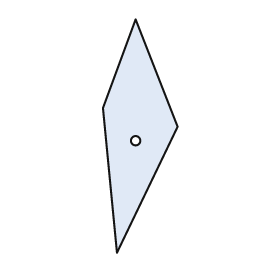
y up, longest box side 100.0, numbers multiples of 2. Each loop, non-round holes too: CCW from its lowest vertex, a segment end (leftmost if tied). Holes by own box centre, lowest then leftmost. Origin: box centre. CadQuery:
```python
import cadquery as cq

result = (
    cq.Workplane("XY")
    .moveTo(-10.0, -50.0)
    .lineTo(16.0, 4.0)
    .lineTo(-2.0, 50.0)
    .lineTo(-16.0, 12.0)
    .close()
    .moveTo(-2.0, -2.0)
    .circle(2.0)
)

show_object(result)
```